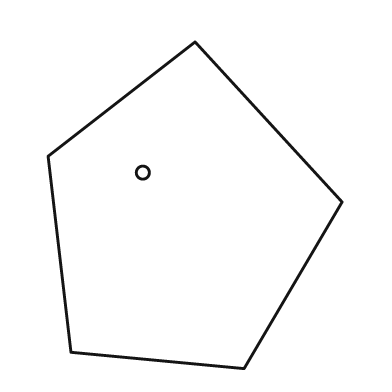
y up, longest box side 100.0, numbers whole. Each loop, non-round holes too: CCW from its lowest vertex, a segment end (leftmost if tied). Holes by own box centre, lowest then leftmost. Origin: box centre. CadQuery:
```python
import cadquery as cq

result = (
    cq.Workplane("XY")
    .moveTo(15.0, -50.0)
    .lineTo(45.0, 1.0)
    .lineTo(0.0, 50.0)
    .lineTo(-45.0, 15.0)
    .lineTo(-38.0, -45.0)
    .close()
    .moveTo(-16.0, 10.0)
    .circle(2.0)
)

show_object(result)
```